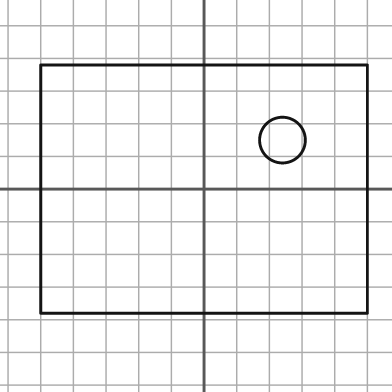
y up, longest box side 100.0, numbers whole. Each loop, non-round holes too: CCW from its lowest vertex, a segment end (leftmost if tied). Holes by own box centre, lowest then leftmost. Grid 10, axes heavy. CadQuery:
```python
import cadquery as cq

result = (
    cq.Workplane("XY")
    .moveTo(-50.0, -38.0)
    .lineTo(50.0, -38.0)
    .lineTo(50.0, 38.0)
    .lineTo(-50.0, 38.0)
    .close()
    .moveTo(24.0, 15.0)
    .circle(7.0)
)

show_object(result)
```